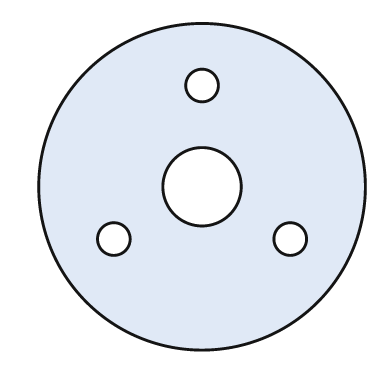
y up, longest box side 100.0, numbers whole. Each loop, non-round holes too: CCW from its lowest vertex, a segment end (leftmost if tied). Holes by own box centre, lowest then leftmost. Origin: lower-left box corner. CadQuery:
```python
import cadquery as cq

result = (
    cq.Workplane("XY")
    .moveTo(50.0, 50.0)
    .circle(50.0)
    .moveTo(23.0, 34.0)
    .circle(5.0)
    .moveTo(77.0, 34.0)
    .circle(5.0)
    .moveTo(50.0, 50.0)
    .circle(12.0)
    .moveTo(50.0, 81.0)
    .circle(5.0)
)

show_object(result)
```